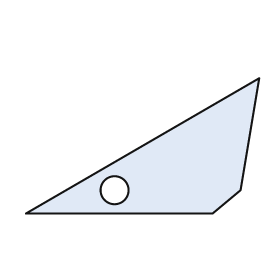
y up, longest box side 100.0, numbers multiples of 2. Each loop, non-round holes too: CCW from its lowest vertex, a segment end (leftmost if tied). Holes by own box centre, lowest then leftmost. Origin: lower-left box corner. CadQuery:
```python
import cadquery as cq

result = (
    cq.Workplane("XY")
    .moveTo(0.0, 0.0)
    .lineTo(80.0, 0.0)
    .lineTo(92.0, 10.0)
    .lineTo(100.0, 58.0)
    .close()
    .moveTo(38.0, 10.0)
    .circle(6.0)
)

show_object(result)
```